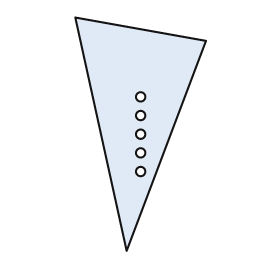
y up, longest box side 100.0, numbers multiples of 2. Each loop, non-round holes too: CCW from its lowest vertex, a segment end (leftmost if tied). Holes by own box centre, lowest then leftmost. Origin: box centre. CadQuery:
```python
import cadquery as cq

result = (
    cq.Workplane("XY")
    .moveTo(-6.0, -50.0)
    .lineTo(28.0, 40.0)
    .lineTo(-28.0, 50.0)
    .close()
    .moveTo(0.0, -16.0)
    .circle(2.0)
    .moveTo(0.0, -8.0)
    .circle(2.0)
    .moveTo(0.0, 0.0)
    .circle(2.0)
    .moveTo(0.0, 8.0)
    .circle(2.0)
    .moveTo(0.0, 16.0)
    .circle(2.0)
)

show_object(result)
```